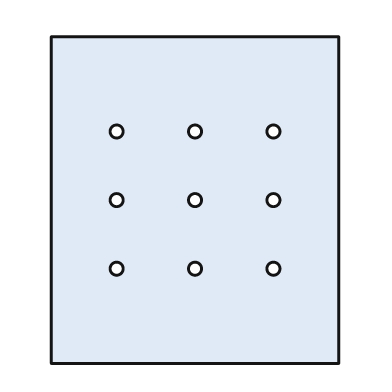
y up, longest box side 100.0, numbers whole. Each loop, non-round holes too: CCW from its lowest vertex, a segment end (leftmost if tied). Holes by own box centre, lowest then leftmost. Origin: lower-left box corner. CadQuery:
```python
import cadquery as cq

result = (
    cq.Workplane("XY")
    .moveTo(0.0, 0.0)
    .lineTo(88.0, 0.0)
    .lineTo(88.0, 100.0)
    .lineTo(0.0, 100.0)
    .close()
    .moveTo(20.0, 29.0)
    .circle(2.0)
    .moveTo(44.0, 29.0)
    .circle(2.0)
    .moveTo(68.0, 29.0)
    .circle(2.0)
    .moveTo(20.0, 50.0)
    .circle(2.0)
    .moveTo(44.0, 50.0)
    .circle(2.0)
    .moveTo(68.0, 50.0)
    .circle(2.0)
    .moveTo(20.0, 71.0)
    .circle(2.0)
    .moveTo(44.0, 71.0)
    .circle(2.0)
    .moveTo(68.0, 71.0)
    .circle(2.0)
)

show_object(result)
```